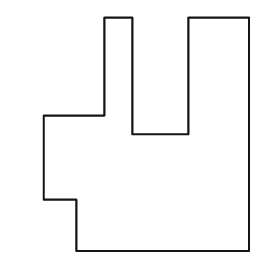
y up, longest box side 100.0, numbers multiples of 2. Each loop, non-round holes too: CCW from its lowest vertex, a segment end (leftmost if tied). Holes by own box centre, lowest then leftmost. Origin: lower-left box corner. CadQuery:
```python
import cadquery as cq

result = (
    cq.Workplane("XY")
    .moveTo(14.0, 0.0)
    .lineTo(88.0, 0.0)
    .lineTo(88.0, 100.0)
    .lineTo(62.0, 100.0)
    .lineTo(62.0, 50.0)
    .lineTo(38.0, 50.0)
    .lineTo(38.0, 100.0)
    .lineTo(26.0, 100.0)
    .lineTo(26.0, 58.0)
    .lineTo(0.0, 58.0)
    .lineTo(0.0, 22.0)
    .lineTo(14.0, 22.0)
    .close()
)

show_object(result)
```